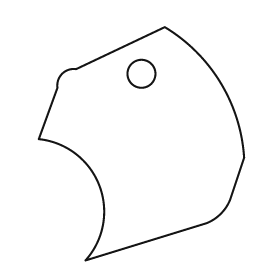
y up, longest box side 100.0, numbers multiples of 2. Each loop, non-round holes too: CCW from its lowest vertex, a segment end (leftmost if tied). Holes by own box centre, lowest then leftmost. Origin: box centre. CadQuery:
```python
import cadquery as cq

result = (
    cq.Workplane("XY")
    .moveTo(-24.0, -50.0)
    .lineTo(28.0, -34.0)
    .threePointArc((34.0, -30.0), (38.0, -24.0))
    .lineTo(44.0, -6.0)
    .threePointArc((34.0, 26.0), (10.0, 50.0))
    .lineTo(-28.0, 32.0)
    .threePointArc((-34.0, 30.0), (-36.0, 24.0))
    .lineTo(-44.0, 2.0)
    .threePointArc((-18.0, -18.0), (-24.0, -50.0))
    .close()
    .moveTo(0.0, 30.0)
    .circle(6.0)
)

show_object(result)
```